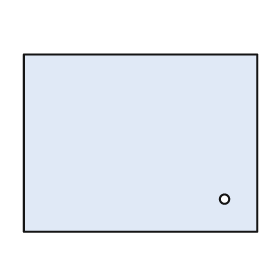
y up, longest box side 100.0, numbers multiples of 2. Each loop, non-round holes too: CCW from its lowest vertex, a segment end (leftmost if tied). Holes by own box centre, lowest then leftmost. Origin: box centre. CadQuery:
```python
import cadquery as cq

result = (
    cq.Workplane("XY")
    .moveTo(-50.0, -38.0)
    .lineTo(50.0, -38.0)
    .lineTo(50.0, 38.0)
    .lineTo(-50.0, 38.0)
    .close()
    .moveTo(36.0, -24.0)
    .circle(2.0)
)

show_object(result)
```